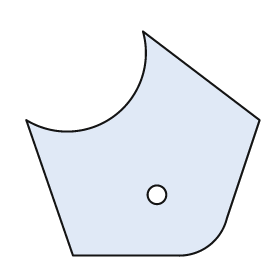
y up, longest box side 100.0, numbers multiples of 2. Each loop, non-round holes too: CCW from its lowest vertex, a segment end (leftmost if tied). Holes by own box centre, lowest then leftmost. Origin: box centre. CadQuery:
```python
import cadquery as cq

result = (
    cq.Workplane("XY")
    .moveTo(-30.0, -48.0)
    .lineTo(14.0, -48.0)
    .threePointArc((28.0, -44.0), (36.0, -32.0))
    .lineTo(50.0, 10.0)
    .lineTo(0.0, 48.0)
    .threePointArc((-12.0, 12.0), (-50.0, 10.0))
    .close()
    .moveTo(6.0, -22.0)
    .circle(4.0)
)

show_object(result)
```